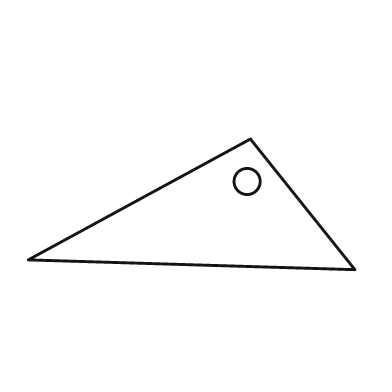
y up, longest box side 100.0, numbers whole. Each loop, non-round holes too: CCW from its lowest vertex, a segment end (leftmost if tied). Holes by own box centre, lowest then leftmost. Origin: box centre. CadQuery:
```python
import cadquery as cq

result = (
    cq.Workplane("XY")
    .moveTo(50.0, -20.0)
    .lineTo(18.0, 20.0)
    .lineTo(-50.0, -17.0)
    .close()
    .moveTo(17.0, 7.0)
    .circle(4.0)
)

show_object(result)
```